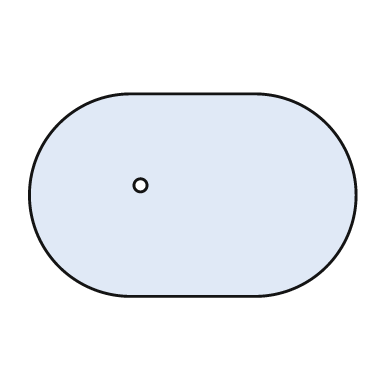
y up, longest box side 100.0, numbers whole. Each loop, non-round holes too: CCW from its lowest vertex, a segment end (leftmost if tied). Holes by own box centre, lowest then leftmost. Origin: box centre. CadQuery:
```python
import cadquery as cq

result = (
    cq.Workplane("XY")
    .moveTo(-19.0, -31.0)
    .lineTo(19.0, -31.0)
    .threePointArc((50.0, 0.0), (19.0, 31.0))
    .lineTo(-19.0, 31.0)
    .threePointArc((-50.0, 0.0), (-19.0, -31.0))
    .close()
    .moveTo(-16.0, 3.0)
    .circle(2.0)
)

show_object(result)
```